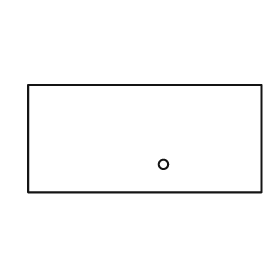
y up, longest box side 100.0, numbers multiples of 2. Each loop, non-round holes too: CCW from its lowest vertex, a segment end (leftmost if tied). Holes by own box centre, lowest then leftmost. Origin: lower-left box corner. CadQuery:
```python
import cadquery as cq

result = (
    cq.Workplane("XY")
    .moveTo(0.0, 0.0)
    .lineTo(100.0, 0.0)
    .lineTo(100.0, 46.0)
    .lineTo(0.0, 46.0)
    .close()
    .moveTo(58.0, 12.0)
    .circle(2.0)
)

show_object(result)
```